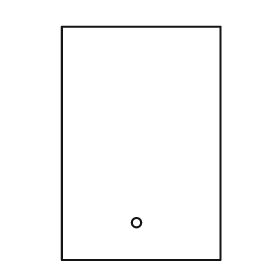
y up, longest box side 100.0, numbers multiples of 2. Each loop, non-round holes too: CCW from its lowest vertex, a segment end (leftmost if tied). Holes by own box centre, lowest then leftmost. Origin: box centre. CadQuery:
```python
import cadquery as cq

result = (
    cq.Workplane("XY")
    .moveTo(-34.0, -50.0)
    .lineTo(34.0, -50.0)
    .lineTo(34.0, 50.0)
    .lineTo(-34.0, 50.0)
    .close()
    .moveTo(-2.0, -34.0)
    .circle(2.0)
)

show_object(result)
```